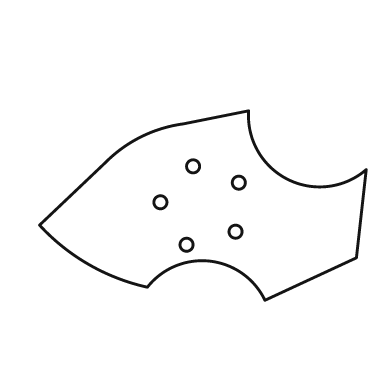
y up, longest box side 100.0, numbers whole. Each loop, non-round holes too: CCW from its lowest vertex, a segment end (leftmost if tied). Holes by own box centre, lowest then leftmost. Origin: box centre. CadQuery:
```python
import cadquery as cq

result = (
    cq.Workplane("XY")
    .moveTo(19.0, -29.0)
    .lineTo(47.0, -16.0)
    .lineTo(50.0, 11.0)
    .threePointArc((26.0, 8.0), (14.0, 29.0))
    .lineTo(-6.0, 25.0)
    .threePointArc((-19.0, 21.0), (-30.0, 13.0))
    .lineTo(-50.0, -6.0)
    .threePointArc((-35.0, -18.0), (-17.0, -25.0))
    .threePointArc((2.0, -17.0), (19.0, -29.0))
    .close()
    .moveTo(-5.0, -12.0)
    .circle(2.0)
    .moveTo(10.0, -8.0)
    .circle(2.0)
    .moveTo(-13.0, 1.0)
    .circle(2.0)
    .moveTo(11.0, 7.0)
    .circle(2.0)
    .moveTo(-3.0, 12.0)
    .circle(2.0)
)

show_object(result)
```